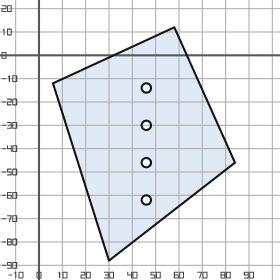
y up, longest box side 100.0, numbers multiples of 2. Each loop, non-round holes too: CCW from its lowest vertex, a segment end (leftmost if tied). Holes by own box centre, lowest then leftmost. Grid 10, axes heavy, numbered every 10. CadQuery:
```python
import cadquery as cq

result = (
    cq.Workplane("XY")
    .moveTo(30.0, -88.0)
    .lineTo(84.0, -46.0)
    .lineTo(58.0, 12.0)
    .lineTo(6.0, -12.0)
    .close()
    .moveTo(46.0, -62.0)
    .circle(2.0)
    .moveTo(46.0, -46.0)
    .circle(2.0)
    .moveTo(46.0, -30.0)
    .circle(2.0)
    .moveTo(46.0, -14.0)
    .circle(2.0)
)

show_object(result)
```